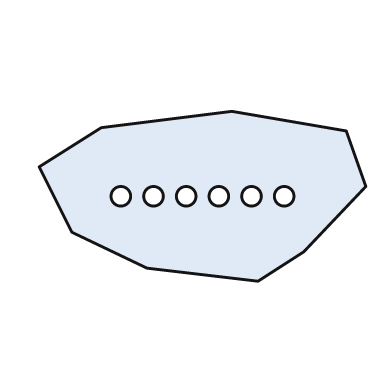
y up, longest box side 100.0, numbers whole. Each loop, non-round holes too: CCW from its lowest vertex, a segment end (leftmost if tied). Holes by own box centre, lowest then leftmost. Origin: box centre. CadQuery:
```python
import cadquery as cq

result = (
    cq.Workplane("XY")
    .moveTo(17.0, -26.0)
    .lineTo(31.0, -17.0)
    .lineTo(50.0, 3.0)
    .lineTo(44.0, 20.0)
    .lineTo(9.0, 26.0)
    .lineTo(-31.0, 21.0)
    .lineTo(-50.0, 9.0)
    .lineTo(-40.0, -11.0)
    .lineTo(-17.0, -22.0)
    .close()
    .moveTo(-25.0, 0.0)
    .circle(3.0)
    .moveTo(-15.0, 0.0)
    .circle(3.0)
    .moveTo(-5.0, 0.0)
    .circle(3.0)
    .moveTo(5.0, 0.0)
    .circle(3.0)
    .moveTo(15.0, 0.0)
    .circle(3.0)
    .moveTo(25.0, 0.0)
    .circle(3.0)
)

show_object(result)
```